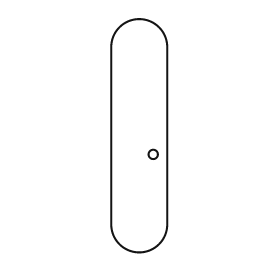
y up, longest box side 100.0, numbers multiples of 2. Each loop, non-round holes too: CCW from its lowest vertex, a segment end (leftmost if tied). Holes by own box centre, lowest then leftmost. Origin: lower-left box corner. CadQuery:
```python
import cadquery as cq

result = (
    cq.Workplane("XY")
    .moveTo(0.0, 12.0)
    .threePointArc((12.0, 0.0), (24.0, 12.0))
    .lineTo(24.0, 88.0)
    .threePointArc((12.0, 100.0), (0.0, 88.0))
    .close()
    .moveTo(18.0, 42.0)
    .circle(2.0)
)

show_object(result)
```